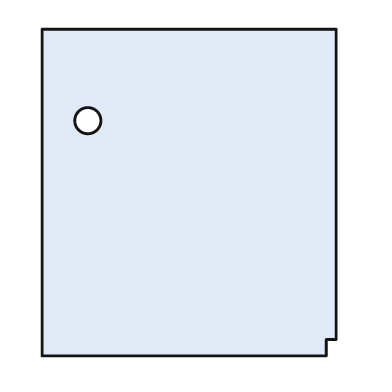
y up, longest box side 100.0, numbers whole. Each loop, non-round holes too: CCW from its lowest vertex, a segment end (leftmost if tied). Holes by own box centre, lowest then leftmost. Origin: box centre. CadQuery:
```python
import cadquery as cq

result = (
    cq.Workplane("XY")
    .moveTo(-45.0, -50.0)
    .lineTo(42.0, -50.0)
    .lineTo(42.0, -45.0)
    .lineTo(45.0, -45.0)
    .lineTo(45.0, 50.0)
    .lineTo(-45.0, 50.0)
    .close()
    .moveTo(-31.0, 22.0)
    .circle(4.0)
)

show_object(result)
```